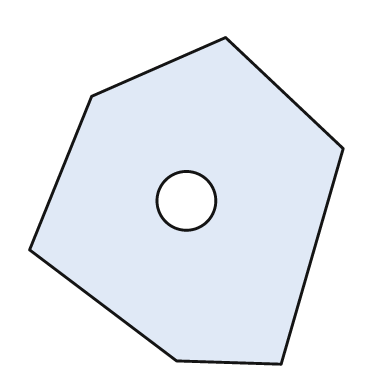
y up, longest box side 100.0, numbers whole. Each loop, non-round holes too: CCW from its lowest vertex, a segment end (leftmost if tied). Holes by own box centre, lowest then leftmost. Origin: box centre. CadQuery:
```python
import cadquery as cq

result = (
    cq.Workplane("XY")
    .moveTo(29.0, -50.0)
    .lineTo(48.0, 16.0)
    .lineTo(12.0, 50.0)
    .lineTo(-29.0, 32.0)
    .lineTo(-48.0, -15.0)
    .lineTo(-3.0, -49.0)
    .close()
    .moveTo(0.0, 0.0)
    .circle(9.0)
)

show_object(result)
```